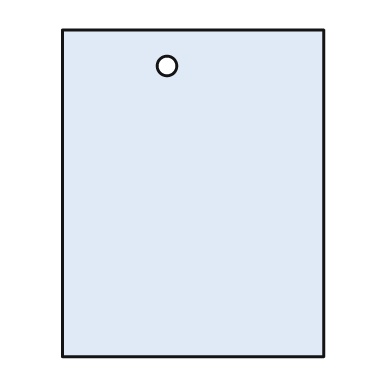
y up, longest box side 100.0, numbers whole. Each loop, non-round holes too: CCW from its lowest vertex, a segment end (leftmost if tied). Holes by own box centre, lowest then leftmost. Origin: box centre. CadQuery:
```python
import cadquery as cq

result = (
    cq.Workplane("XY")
    .moveTo(-40.0, -50.0)
    .lineTo(40.0, -50.0)
    .lineTo(40.0, 50.0)
    .lineTo(-40.0, 50.0)
    .close()
    .moveTo(-8.0, 39.0)
    .circle(3.0)
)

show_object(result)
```